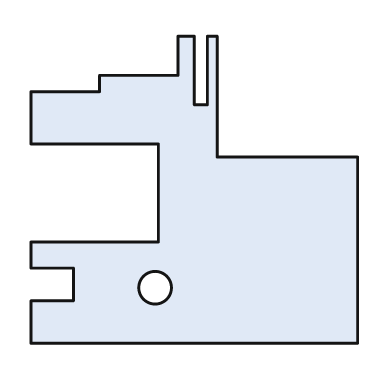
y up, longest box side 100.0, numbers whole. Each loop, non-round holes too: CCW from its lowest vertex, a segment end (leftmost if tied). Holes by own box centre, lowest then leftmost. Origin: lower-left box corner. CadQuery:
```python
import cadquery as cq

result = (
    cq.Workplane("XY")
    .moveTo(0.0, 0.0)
    .lineTo(100.0, 0.0)
    .lineTo(100.0, 57.0)
    .lineTo(57.0, 57.0)
    .lineTo(57.0, 94.0)
    .lineTo(54.0, 94.0)
    .lineTo(54.0, 73.0)
    .lineTo(50.0, 73.0)
    .lineTo(50.0, 94.0)
    .lineTo(45.0, 94.0)
    .lineTo(45.0, 82.0)
    .lineTo(21.0, 82.0)
    .lineTo(21.0, 77.0)
    .lineTo(0.0, 77.0)
    .lineTo(0.0, 61.0)
    .lineTo(39.0, 61.0)
    .lineTo(39.0, 31.0)
    .lineTo(0.0, 31.0)
    .lineTo(0.0, 23.0)
    .lineTo(13.0, 23.0)
    .lineTo(13.0, 13.0)
    .lineTo(0.0, 13.0)
    .close()
    .moveTo(38.0, 17.0)
    .circle(5.0)
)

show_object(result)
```